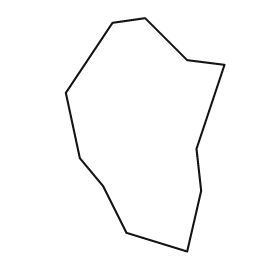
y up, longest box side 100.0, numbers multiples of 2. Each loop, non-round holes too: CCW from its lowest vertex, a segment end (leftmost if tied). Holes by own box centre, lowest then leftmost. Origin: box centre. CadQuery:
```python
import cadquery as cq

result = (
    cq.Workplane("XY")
    .moveTo(18.0, -50.0)
    .lineTo(24.0, -24.0)
    .lineTo(22.0, -6.0)
    .lineTo(34.0, 30.0)
    .lineTo(18.0, 32.0)
    .lineTo(0.0, 50.0)
    .lineTo(-14.0, 48.0)
    .lineTo(-34.0, 18.0)
    .lineTo(-28.0, -10.0)
    .lineTo(-18.0, -22.0)
    .lineTo(-8.0, -42.0)
    .close()
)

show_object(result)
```